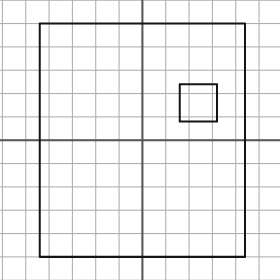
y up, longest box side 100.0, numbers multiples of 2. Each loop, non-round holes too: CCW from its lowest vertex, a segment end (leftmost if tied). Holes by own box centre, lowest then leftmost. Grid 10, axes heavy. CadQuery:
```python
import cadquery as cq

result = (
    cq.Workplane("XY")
    .moveTo(-44.0, -50.0)
    .lineTo(44.0, -50.0)
    .lineTo(44.0, 50.0)
    .lineTo(-44.0, 50.0)
    .close()
    .moveTo(16.0, 8.0)
    .lineTo(32.0, 8.0)
    .lineTo(32.0, 24.0)
    .lineTo(16.0, 24.0)
    .close()
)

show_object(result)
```